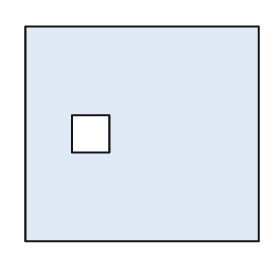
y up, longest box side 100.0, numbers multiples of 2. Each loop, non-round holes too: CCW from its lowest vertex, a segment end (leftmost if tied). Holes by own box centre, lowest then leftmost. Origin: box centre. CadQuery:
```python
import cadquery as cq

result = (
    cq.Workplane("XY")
    .moveTo(-50.0, -46.0)
    .lineTo(50.0, -46.0)
    .lineTo(50.0, 46.0)
    .lineTo(-50.0, 46.0)
    .close()
    .moveTo(-30.0, -8.0)
    .lineTo(-14.0, -8.0)
    .lineTo(-14.0, 8.0)
    .lineTo(-30.0, 8.0)
    .close()
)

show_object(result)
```